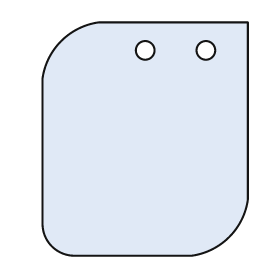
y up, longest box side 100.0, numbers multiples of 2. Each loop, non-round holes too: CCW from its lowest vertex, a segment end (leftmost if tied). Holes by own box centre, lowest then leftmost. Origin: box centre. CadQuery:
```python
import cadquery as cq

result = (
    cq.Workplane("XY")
    .moveTo(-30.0, -50.0)
    .lineTo(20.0, -50.0)
    .threePointArc((36.0, -42.0), (44.0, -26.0))
    .lineTo(44.0, 50.0)
    .lineTo(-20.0, 50.0)
    .threePointArc((-36.0, 42.0), (-44.0, 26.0))
    .lineTo(-44.0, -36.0)
    .threePointArc((-40.0, -46.0), (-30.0, -50.0))
    .close()
    .moveTo(0.0, 38.0)
    .circle(4.0)
    .moveTo(26.0, 38.0)
    .circle(4.0)
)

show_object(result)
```